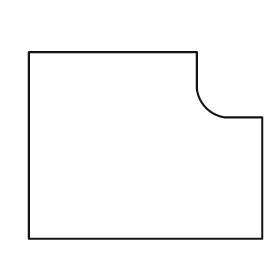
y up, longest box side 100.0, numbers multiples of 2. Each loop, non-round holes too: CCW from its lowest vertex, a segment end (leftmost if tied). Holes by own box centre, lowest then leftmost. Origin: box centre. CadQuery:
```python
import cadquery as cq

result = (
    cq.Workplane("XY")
    .moveTo(-50.0, -40.0)
    .lineTo(50.0, -40.0)
    .lineTo(50.0, 12.0)
    .lineTo(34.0, 12.0)
    .threePointArc((26.0, 16.0), (22.0, 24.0))
    .lineTo(22.0, 40.0)
    .lineTo(-50.0, 40.0)
    .close()
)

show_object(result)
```